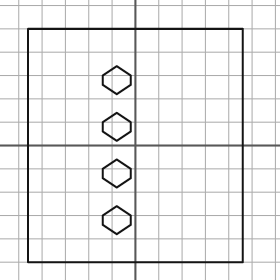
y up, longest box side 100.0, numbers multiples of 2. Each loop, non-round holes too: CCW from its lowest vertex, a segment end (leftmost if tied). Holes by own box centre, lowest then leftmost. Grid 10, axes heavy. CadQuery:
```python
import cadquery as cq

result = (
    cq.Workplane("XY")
    .moveTo(-46.0, -50.0)
    .lineTo(46.0, -50.0)
    .lineTo(46.0, 50.0)
    .lineTo(-46.0, 50.0)
    .close()
    .moveTo(-8.0, -38.0)
    .lineTo(-2.0, -34.0)
    .lineTo(-2.0, -30.0)
    .lineTo(-8.0, -26.0)
    .lineTo(-14.0, -30.0)
    .lineTo(-14.0, -34.0)
    .close()
    .moveTo(-8.0, -18.0)
    .lineTo(-2.0, -14.0)
    .lineTo(-2.0, -10.0)
    .lineTo(-8.0, -6.0)
    .lineTo(-14.0, -10.0)
    .lineTo(-14.0, -14.0)
    .close()
    .moveTo(-8.0, 2.0)
    .lineTo(-2.0, 6.0)
    .lineTo(-2.0, 10.0)
    .lineTo(-8.0, 14.0)
    .lineTo(-14.0, 10.0)
    .lineTo(-14.0, 6.0)
    .close()
    .moveTo(-8.0, 22.0)
    .lineTo(-2.0, 26.0)
    .lineTo(-2.0, 30.0)
    .lineTo(-8.0, 34.0)
    .lineTo(-14.0, 30.0)
    .lineTo(-14.0, 26.0)
    .close()
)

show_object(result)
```